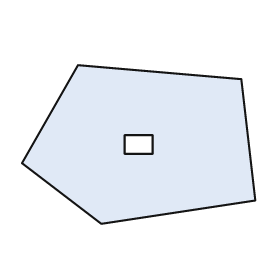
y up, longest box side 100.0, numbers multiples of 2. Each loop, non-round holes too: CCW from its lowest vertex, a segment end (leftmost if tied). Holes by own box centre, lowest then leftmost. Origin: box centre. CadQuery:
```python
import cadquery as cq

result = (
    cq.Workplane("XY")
    .moveTo(-16.0, -34.0)
    .lineTo(50.0, -24.0)
    .lineTo(44.0, 28.0)
    .lineTo(-26.0, 34.0)
    .lineTo(-50.0, -8.0)
    .close()
    .moveTo(-6.0, -4.0)
    .lineTo(6.0, -4.0)
    .lineTo(6.0, 4.0)
    .lineTo(-6.0, 4.0)
    .close()
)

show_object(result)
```